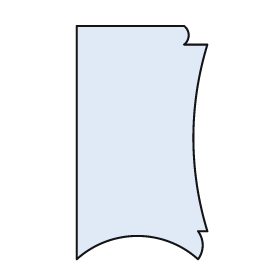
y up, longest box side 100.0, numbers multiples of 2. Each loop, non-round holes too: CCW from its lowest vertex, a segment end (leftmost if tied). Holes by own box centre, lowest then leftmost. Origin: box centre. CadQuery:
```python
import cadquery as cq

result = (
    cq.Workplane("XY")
    .moveTo(-28.0, -50.0)
    .threePointArc((-2.0, -40.0), (24.0, -50.0))
    .threePointArc((26.0, -44.0), (24.0, -38.0))
    .lineTo(28.0, -38.0)
    .threePointArc((22.0, 2.0), (28.0, 42.0))
    .lineTo(18.0, 42.0)
    .threePointArc((20.0, 46.0), (18.0, 50.0))
    .lineTo(-28.0, 50.0)
    .close()
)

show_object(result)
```